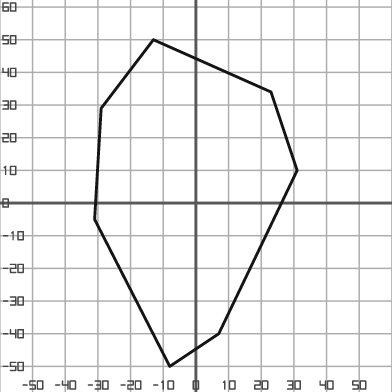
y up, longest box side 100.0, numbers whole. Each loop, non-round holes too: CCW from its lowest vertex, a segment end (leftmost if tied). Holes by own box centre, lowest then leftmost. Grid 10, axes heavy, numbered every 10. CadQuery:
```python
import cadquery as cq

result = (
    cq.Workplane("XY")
    .moveTo(-8.0, -50.0)
    .lineTo(7.0, -40.0)
    .lineTo(31.0, 10.0)
    .lineTo(23.0, 34.0)
    .lineTo(-13.0, 50.0)
    .lineTo(-29.0, 29.0)
    .lineTo(-31.0, -5.0)
    .close()
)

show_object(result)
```